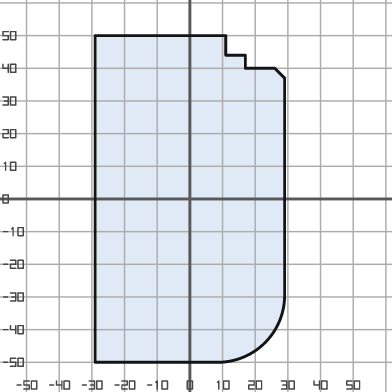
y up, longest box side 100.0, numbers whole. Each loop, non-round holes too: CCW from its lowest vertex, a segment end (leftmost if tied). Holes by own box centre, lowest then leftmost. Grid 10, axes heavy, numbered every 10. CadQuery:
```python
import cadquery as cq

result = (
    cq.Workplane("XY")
    .moveTo(-29.0, -50.0)
    .lineTo(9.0, -50.0)
    .threePointArc((23.0, -44.0), (29.0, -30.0))
    .lineTo(29.0, 37.0)
    .lineTo(26.0, 40.0)
    .lineTo(17.0, 40.0)
    .lineTo(17.0, 44.0)
    .lineTo(11.0, 44.0)
    .lineTo(11.0, 50.0)
    .lineTo(-29.0, 50.0)
    .close()
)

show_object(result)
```